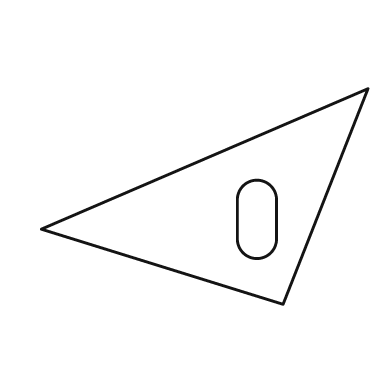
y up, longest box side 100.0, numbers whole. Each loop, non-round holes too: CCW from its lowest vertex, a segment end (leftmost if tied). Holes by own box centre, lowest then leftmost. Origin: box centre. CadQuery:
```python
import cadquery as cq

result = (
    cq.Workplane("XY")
    .moveTo(24.0, -33.0)
    .lineTo(50.0, 33.0)
    .lineTo(-50.0, -10.0)
    .close()
    .moveTo(10.0, -13.0)
    .threePointArc((16.0, -19.0), (22.0, -13.0))
    .lineTo(22.0, -1.0)
    .threePointArc((16.0, 5.0), (10.0, -1.0))
    .close()
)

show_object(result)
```